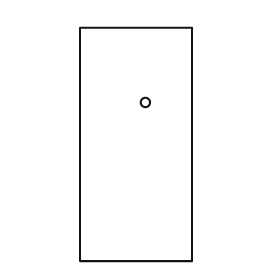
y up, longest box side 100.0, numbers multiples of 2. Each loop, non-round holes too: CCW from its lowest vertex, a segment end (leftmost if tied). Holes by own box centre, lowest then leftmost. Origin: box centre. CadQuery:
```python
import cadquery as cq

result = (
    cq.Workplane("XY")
    .moveTo(-24.0, -50.0)
    .lineTo(24.0, -50.0)
    .lineTo(24.0, 50.0)
    .lineTo(-24.0, 50.0)
    .close()
    .moveTo(4.0, 18.0)
    .circle(2.0)
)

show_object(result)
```